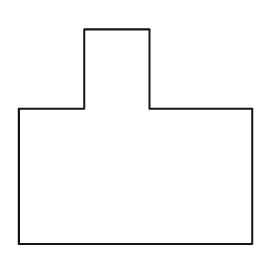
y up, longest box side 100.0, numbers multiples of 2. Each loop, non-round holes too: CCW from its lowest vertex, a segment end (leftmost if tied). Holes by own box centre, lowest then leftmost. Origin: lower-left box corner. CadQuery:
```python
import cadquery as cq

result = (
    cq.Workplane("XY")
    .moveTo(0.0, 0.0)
    .lineTo(100.0, 0.0)
    .lineTo(100.0, 58.0)
    .lineTo(56.0, 58.0)
    .lineTo(56.0, 92.0)
    .lineTo(28.0, 92.0)
    .lineTo(28.0, 58.0)
    .lineTo(0.0, 58.0)
    .close()
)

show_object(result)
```